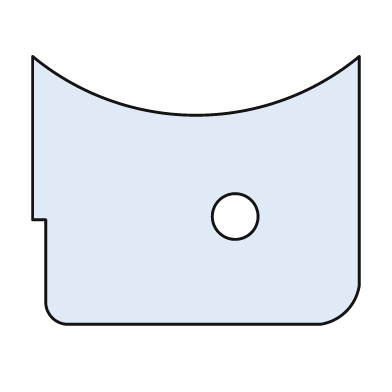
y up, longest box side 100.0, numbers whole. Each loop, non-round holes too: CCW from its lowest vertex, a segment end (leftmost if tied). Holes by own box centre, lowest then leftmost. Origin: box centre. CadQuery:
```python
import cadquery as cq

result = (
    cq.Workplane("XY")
    .moveTo(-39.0, -41.0)
    .lineTo(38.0, -41.0)
    .threePointArc((46.0, -37.0), (50.0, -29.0))
    .lineTo(50.0, 41.0)
    .threePointArc((0.0, 23.0), (-50.0, 41.0))
    .lineTo(-50.0, -9.0)
    .lineTo(-46.0, -9.0)
    .lineTo(-46.0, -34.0)
    .threePointArc((-44.0, -39.0), (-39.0, -41.0))
    .close()
    .moveTo(12.0, -8.0)
    .circle(7.0)
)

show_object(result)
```